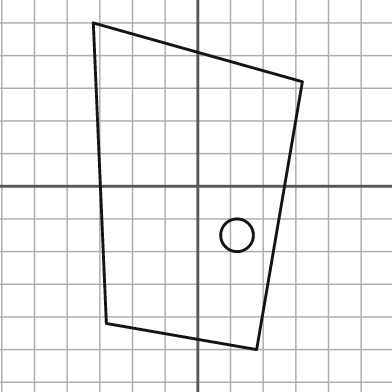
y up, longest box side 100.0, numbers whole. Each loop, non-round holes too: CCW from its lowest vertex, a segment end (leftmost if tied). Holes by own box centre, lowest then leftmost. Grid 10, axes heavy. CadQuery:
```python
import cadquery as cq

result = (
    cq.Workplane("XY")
    .moveTo(18.0, -50.0)
    .lineTo(32.0, 32.0)
    .lineTo(-32.0, 50.0)
    .lineTo(-28.0, -42.0)
    .close()
    .moveTo(12.0, -15.0)
    .circle(5.0)
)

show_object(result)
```